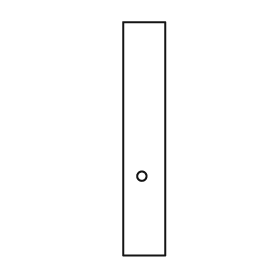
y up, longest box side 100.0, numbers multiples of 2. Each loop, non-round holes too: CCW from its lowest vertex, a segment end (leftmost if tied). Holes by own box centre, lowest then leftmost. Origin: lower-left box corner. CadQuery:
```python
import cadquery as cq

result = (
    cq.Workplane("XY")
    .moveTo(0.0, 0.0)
    .lineTo(18.0, 0.0)
    .lineTo(18.0, 100.0)
    .lineTo(0.0, 100.0)
    .close()
    .moveTo(8.0, 34.0)
    .circle(2.0)
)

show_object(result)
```